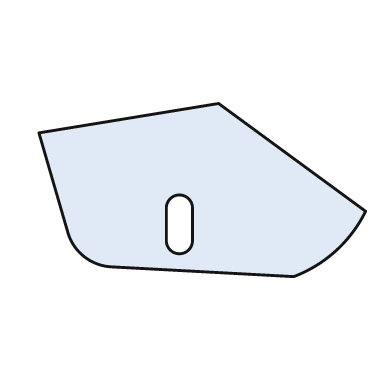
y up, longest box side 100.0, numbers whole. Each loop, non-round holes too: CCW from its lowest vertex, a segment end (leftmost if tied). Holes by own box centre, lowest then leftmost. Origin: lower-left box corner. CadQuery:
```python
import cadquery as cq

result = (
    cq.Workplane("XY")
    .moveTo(78.0, 0.0)
    .threePointArc((91.0, 8.0), (100.0, 20.0))
    .lineTo(55.0, 53.0)
    .lineTo(0.0, 44.0)
    .lineTo(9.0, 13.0)
    .threePointArc((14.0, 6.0), (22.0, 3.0))
    .close()
    .moveTo(39.0, 11.0)
    .threePointArc((43.0, 7.0), (47.0, 11.0))
    .lineTo(47.0, 21.0)
    .threePointArc((43.0, 25.0), (39.0, 21.0))
    .close()
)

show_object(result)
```